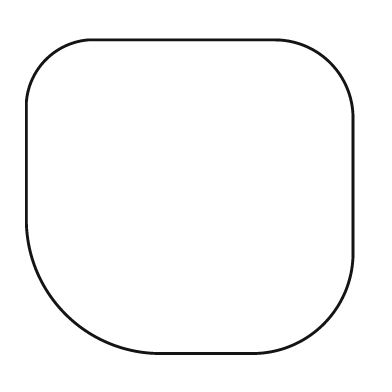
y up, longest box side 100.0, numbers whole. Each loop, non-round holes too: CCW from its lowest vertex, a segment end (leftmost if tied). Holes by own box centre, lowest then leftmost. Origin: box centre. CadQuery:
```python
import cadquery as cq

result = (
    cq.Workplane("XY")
    .moveTo(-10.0, -48.0)
    .lineTo(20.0, -48.0)
    .threePointArc((41.0, -39.0), (50.0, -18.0))
    .lineTo(50.0, 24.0)
    .threePointArc((43.0, 41.0), (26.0, 48.0))
    .lineTo(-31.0, 48.0)
    .threePointArc((-44.0, 42.0), (-50.0, 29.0))
    .lineTo(-50.0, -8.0)
    .threePointArc((-38.0, -36.0), (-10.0, -48.0))
    .close()
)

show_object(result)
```